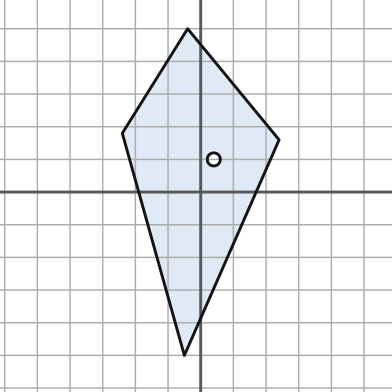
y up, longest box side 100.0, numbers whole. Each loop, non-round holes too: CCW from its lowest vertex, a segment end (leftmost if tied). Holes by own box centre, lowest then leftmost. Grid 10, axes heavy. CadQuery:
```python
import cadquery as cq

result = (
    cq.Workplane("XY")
    .moveTo(-5.0, -50.0)
    .lineTo(24.0, 16.0)
    .lineTo(-4.0, 50.0)
    .lineTo(-24.0, 18.0)
    .close()
    .moveTo(4.0, 10.0)
    .circle(2.0)
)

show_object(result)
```